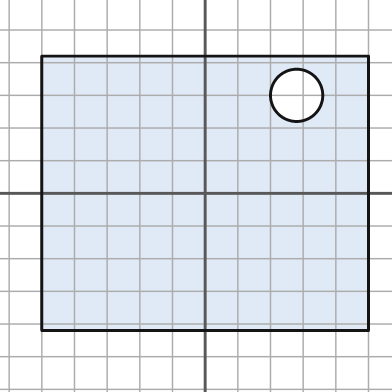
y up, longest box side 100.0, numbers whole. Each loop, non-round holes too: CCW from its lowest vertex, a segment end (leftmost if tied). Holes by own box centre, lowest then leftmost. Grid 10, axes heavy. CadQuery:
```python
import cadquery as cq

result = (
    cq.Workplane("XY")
    .moveTo(-50.0, -42.0)
    .lineTo(50.0, -42.0)
    .lineTo(50.0, 42.0)
    .lineTo(-50.0, 42.0)
    .close()
    .moveTo(28.0, 30.0)
    .circle(8.0)
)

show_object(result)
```